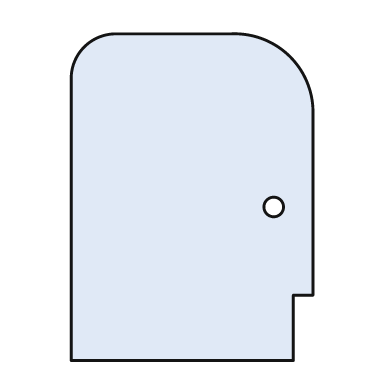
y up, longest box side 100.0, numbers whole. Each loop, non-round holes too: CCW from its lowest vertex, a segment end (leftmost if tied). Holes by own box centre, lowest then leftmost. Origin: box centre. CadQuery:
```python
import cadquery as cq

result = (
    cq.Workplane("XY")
    .moveTo(-37.0, -50.0)
    .lineTo(31.0, -50.0)
    .lineTo(31.0, -30.0)
    .lineTo(37.0, -30.0)
    .lineTo(37.0, 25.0)
    .threePointArc((30.0, 43.0), (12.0, 50.0))
    .lineTo(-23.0, 50.0)
    .threePointArc((-33.0, 46.0), (-37.0, 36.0))
    .close()
    .moveTo(25.0, -3.0)
    .circle(3.0)
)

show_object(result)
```